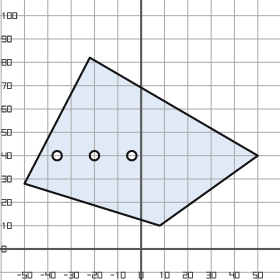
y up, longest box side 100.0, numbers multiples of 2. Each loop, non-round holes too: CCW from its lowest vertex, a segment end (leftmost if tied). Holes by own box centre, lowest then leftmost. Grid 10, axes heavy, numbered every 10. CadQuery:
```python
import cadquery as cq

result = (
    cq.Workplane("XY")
    .moveTo(8.0, 10.0)
    .lineTo(50.0, 40.0)
    .lineTo(-22.0, 82.0)
    .lineTo(-50.0, 28.0)
    .close()
    .moveTo(-36.0, 40.0)
    .circle(2.0)
    .moveTo(-20.0, 40.0)
    .circle(2.0)
    .moveTo(-4.0, 40.0)
    .circle(2.0)
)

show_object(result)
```